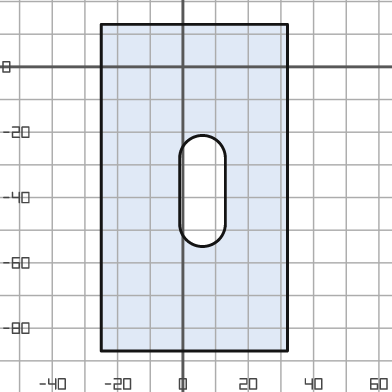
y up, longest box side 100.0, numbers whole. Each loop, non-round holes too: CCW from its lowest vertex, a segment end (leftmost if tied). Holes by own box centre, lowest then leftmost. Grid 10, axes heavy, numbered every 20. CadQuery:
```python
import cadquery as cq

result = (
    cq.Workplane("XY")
    .moveTo(-25.0, -87.0)
    .lineTo(32.0, -87.0)
    .lineTo(32.0, 13.0)
    .lineTo(-25.0, 13.0)
    .close()
    .moveTo(-1.0, -48.0)
    .threePointArc((6.0, -55.0), (13.0, -48.0))
    .lineTo(13.0, -28.0)
    .threePointArc((6.0, -21.0), (-1.0, -28.0))
    .close()
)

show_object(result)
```